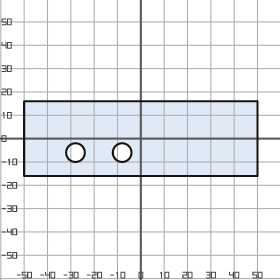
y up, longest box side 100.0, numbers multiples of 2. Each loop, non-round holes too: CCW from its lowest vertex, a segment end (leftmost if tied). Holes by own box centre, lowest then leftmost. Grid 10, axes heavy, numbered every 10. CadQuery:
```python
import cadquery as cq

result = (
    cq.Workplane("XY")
    .moveTo(-50.0, -16.0)
    .lineTo(50.0, -16.0)
    .lineTo(50.0, 16.0)
    .lineTo(-50.0, 16.0)
    .close()
    .moveTo(-28.0, -6.0)
    .circle(4.0)
    .moveTo(-8.0, -6.0)
    .circle(4.0)
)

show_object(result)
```